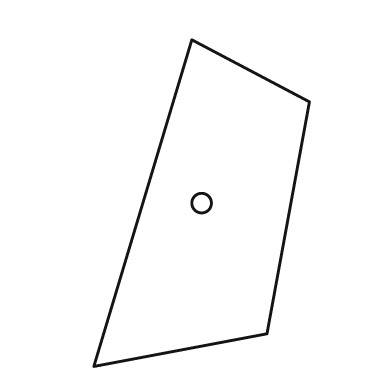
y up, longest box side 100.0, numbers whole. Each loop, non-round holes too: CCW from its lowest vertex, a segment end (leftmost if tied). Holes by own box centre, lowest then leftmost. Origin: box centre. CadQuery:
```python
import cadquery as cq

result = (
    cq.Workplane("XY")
    .moveTo(-33.0, -50.0)
    .lineTo(20.0, -40.0)
    .lineTo(33.0, 31.0)
    .lineTo(-3.0, 50.0)
    .close()
    .moveTo(0.0, 0.0)
    .circle(3.0)
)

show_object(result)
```